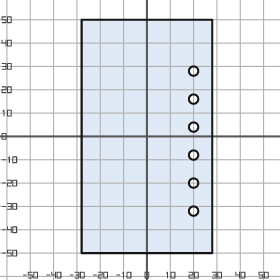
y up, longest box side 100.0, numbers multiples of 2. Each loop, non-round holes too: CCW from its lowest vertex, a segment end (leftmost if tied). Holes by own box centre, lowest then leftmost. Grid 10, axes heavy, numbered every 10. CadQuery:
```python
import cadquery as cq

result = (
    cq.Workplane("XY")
    .moveTo(-28.0, -50.0)
    .lineTo(28.0, -50.0)
    .lineTo(28.0, 50.0)
    .lineTo(-28.0, 50.0)
    .close()
    .moveTo(20.0, -32.0)
    .circle(2.0)
    .moveTo(20.0, -20.0)
    .circle(2.0)
    .moveTo(20.0, -8.0)
    .circle(2.0)
    .moveTo(20.0, 4.0)
    .circle(2.0)
    .moveTo(20.0, 16.0)
    .circle(2.0)
    .moveTo(20.0, 28.0)
    .circle(2.0)
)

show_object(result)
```